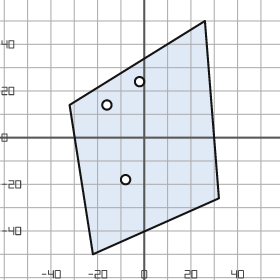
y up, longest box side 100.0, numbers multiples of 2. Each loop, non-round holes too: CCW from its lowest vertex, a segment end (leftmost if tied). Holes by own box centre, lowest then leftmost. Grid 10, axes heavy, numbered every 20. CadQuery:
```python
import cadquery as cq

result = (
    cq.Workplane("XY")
    .moveTo(-22.0, -50.0)
    .lineTo(32.0, -26.0)
    .lineTo(26.0, 50.0)
    .lineTo(-32.0, 14.0)
    .close()
    .moveTo(-8.0, -18.0)
    .circle(2.0)
    .moveTo(-16.0, 14.0)
    .circle(2.0)
    .moveTo(-2.0, 24.0)
    .circle(2.0)
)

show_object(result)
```